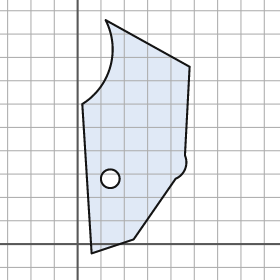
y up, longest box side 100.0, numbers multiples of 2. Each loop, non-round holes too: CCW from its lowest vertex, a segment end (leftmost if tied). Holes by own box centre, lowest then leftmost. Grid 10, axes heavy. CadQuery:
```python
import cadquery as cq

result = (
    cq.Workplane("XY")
    .moveTo(6.0, -4.0)
    .lineTo(24.0, 2.0)
    .lineTo(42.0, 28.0)
    .threePointArc((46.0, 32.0), (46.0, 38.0))
    .lineTo(48.0, 76.0)
    .lineTo(12.0, 96.0)
    .threePointArc((14.0, 76.0), (2.0, 60.0))
    .close()
    .moveTo(14.0, 28.0)
    .circle(4.0)
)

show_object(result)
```